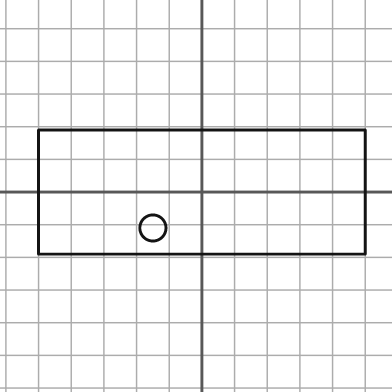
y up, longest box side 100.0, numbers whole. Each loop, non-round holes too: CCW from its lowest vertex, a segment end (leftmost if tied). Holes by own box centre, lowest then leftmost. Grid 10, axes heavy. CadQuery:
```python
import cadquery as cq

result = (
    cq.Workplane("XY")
    .moveTo(-50.0, -19.0)
    .lineTo(50.0, -19.0)
    .lineTo(50.0, 19.0)
    .lineTo(-50.0, 19.0)
    .close()
    .moveTo(-15.0, -11.0)
    .circle(4.0)
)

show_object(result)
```